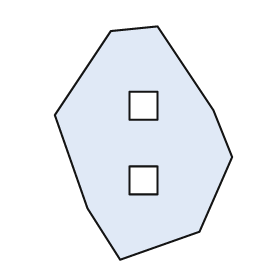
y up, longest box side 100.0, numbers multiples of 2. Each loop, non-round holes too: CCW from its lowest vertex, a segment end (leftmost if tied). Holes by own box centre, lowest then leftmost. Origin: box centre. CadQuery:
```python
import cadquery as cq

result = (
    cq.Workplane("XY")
    .moveTo(-10.0, -50.0)
    .lineTo(24.0, -38.0)
    .lineTo(38.0, -6.0)
    .lineTo(30.0, 14.0)
    .lineTo(6.0, 50.0)
    .lineTo(-14.0, 48.0)
    .lineTo(-38.0, 12.0)
    .lineTo(-24.0, -28.0)
    .close()
    .moveTo(-6.0, -22.0)
    .lineTo(6.0, -22.0)
    .lineTo(6.0, -10.0)
    .lineTo(-6.0, -10.0)
    .close()
    .moveTo(-6.0, 10.0)
    .lineTo(6.0, 10.0)
    .lineTo(6.0, 22.0)
    .lineTo(-6.0, 22.0)
    .close()
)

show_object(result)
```